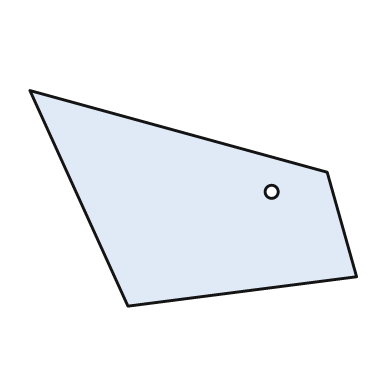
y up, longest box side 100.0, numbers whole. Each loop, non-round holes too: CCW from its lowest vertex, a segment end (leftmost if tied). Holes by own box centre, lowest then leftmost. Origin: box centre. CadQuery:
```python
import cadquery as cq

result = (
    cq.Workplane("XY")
    .moveTo(-20.0, -33.0)
    .lineTo(50.0, -24.0)
    .lineTo(41.0, 8.0)
    .lineTo(-50.0, 33.0)
    .close()
    .moveTo(24.0, 2.0)
    .circle(2.0)
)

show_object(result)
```